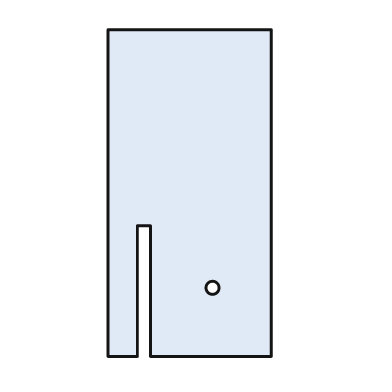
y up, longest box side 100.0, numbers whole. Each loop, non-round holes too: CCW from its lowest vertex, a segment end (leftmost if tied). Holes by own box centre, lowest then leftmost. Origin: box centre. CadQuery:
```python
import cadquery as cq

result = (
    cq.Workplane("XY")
    .moveTo(-25.0, -50.0)
    .lineTo(-16.0, -50.0)
    .lineTo(-16.0, -10.0)
    .lineTo(-12.0, -10.0)
    .lineTo(-12.0, -50.0)
    .lineTo(25.0, -50.0)
    .lineTo(25.0, 50.0)
    .lineTo(-25.0, 50.0)
    .close()
    .moveTo(7.0, -29.0)
    .circle(2.0)
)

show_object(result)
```